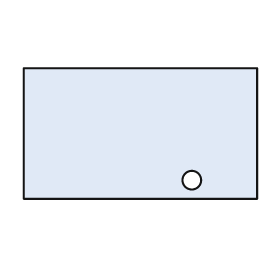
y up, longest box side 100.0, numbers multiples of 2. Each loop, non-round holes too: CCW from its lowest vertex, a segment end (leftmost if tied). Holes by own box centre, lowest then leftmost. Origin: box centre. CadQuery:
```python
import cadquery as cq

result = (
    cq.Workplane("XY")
    .moveTo(-50.0, -28.0)
    .lineTo(50.0, -28.0)
    .lineTo(50.0, 28.0)
    .lineTo(-50.0, 28.0)
    .close()
    .moveTo(22.0, -20.0)
    .circle(4.0)
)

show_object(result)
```